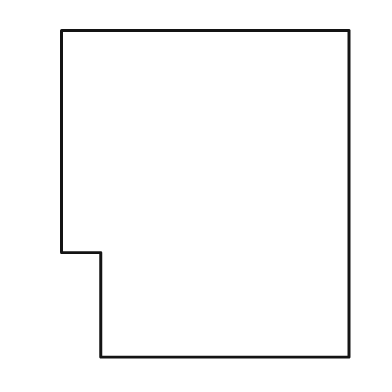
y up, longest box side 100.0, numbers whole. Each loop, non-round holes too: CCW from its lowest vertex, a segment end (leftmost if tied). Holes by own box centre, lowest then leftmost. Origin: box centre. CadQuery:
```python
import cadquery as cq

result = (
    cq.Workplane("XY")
    .moveTo(-32.0, -50.0)
    .lineTo(44.0, -50.0)
    .lineTo(44.0, 50.0)
    .lineTo(-44.0, 50.0)
    .lineTo(-44.0, -18.0)
    .lineTo(-32.0, -18.0)
    .close()
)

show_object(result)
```